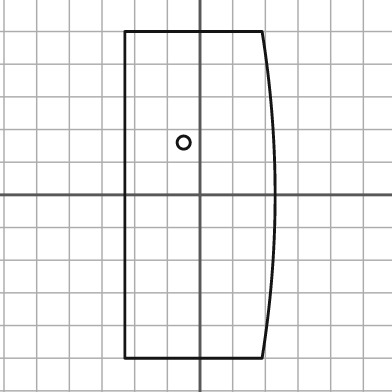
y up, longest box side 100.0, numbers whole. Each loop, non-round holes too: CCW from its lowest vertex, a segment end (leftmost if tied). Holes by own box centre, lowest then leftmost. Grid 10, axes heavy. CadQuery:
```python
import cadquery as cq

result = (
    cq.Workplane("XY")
    .moveTo(-23.0, -50.0)
    .lineTo(19.0, -50.0)
    .threePointArc((23.0, 0.0), (19.0, 50.0))
    .lineTo(-23.0, 50.0)
    .close()
    .moveTo(-5.0, 16.0)
    .circle(2.0)
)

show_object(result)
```